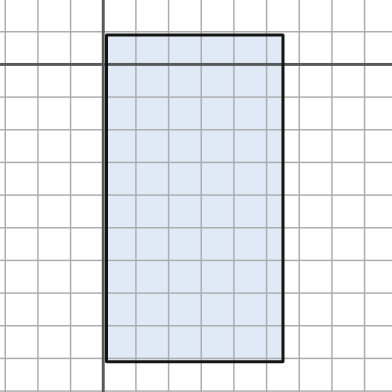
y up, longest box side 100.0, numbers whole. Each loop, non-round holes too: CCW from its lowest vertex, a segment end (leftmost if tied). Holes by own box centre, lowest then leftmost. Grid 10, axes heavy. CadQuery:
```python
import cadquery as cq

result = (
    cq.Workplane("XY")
    .moveTo(1.0, -91.0)
    .lineTo(55.0, -91.0)
    .lineTo(55.0, 9.0)
    .lineTo(1.0, 9.0)
    .close()
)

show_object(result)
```